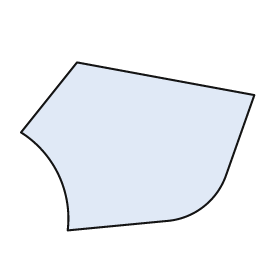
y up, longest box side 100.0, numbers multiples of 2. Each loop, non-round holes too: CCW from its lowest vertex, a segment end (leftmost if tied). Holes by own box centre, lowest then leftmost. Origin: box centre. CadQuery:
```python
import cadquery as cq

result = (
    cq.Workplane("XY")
    .moveTo(-30.0, -36.0)
    .lineTo(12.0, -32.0)
    .threePointArc((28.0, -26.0), (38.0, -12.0))
    .lineTo(50.0, 22.0)
    .lineTo(-26.0, 36.0)
    .lineTo(-50.0, 6.0)
    .threePointArc((-34.0, -12.0), (-30.0, -36.0))
    .close()
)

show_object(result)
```